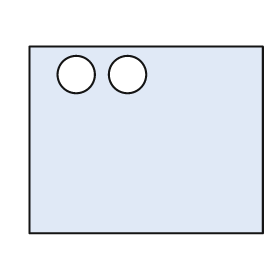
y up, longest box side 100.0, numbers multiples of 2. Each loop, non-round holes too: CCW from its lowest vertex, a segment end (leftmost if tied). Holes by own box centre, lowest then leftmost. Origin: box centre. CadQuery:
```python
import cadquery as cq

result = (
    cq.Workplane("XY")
    .moveTo(-50.0, -40.0)
    .lineTo(50.0, -40.0)
    .lineTo(50.0, 40.0)
    .lineTo(-50.0, 40.0)
    .close()
    .moveTo(-30.0, 28.0)
    .circle(8.0)
    .moveTo(-8.0, 28.0)
    .circle(8.0)
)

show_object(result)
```